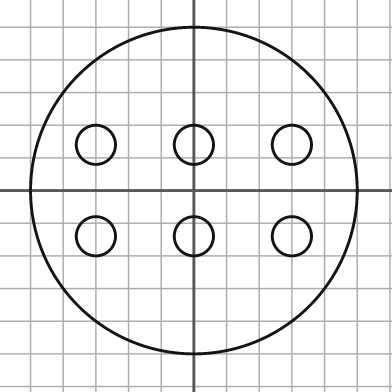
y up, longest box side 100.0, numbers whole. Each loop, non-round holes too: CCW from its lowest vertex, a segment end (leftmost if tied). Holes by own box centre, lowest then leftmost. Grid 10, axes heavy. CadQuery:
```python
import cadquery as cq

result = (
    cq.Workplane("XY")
    .moveTo(0.0, 0.0)
    .circle(50.0)
    .moveTo(-30.0, -14.0)
    .circle(6.0)
    .moveTo(0.0, -14.0)
    .circle(6.0)
    .moveTo(30.0, -14.0)
    .circle(6.0)
    .moveTo(-30.0, 14.0)
    .circle(6.0)
    .moveTo(0.0, 14.0)
    .circle(6.0)
    .moveTo(30.0, 14.0)
    .circle(6.0)
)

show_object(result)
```